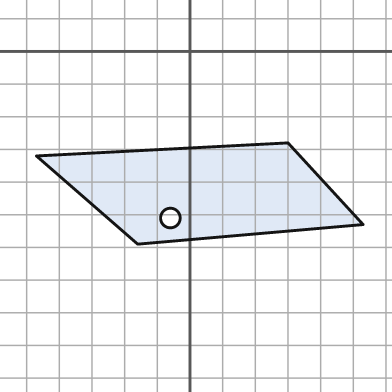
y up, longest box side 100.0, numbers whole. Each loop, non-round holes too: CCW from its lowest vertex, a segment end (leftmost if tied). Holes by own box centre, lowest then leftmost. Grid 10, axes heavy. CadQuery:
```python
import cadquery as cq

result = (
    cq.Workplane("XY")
    .moveTo(-16.0, -59.0)
    .lineTo(53.0, -53.0)
    .lineTo(30.0, -28.0)
    .lineTo(-47.0, -32.0)
    .close()
    .moveTo(-6.0, -51.0)
    .circle(3.0)
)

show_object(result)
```